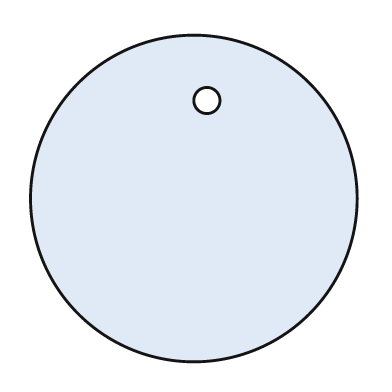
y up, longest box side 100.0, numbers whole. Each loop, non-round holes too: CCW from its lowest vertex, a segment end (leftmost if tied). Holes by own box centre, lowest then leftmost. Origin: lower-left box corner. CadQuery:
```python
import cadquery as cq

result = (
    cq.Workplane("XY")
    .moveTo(50.0, 50.0)
    .circle(50.0)
    .moveTo(54.0, 80.0)
    .circle(4.0)
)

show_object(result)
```